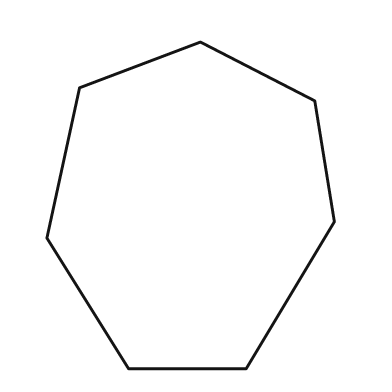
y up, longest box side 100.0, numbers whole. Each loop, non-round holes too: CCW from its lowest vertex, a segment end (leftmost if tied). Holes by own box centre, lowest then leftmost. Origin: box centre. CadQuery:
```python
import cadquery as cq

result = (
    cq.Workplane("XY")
    .moveTo(-19.0, -50.0)
    .lineTo(17.0, -50.0)
    .lineTo(44.0, -5.0)
    .lineTo(38.0, 32.0)
    .lineTo(3.0, 50.0)
    .lineTo(-34.0, 36.0)
    .lineTo(-44.0, -10.0)
    .close()
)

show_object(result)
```